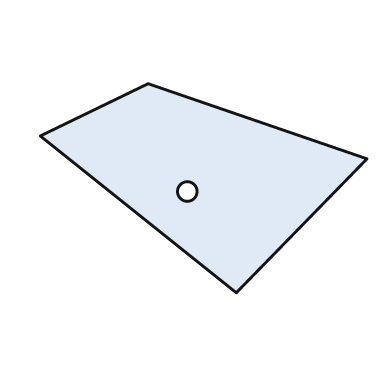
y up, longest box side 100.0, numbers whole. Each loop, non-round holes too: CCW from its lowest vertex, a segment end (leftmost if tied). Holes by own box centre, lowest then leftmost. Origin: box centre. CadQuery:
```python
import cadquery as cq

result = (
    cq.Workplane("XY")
    .moveTo(10.0, -32.0)
    .lineTo(50.0, 9.0)
    .lineTo(-17.0, 32.0)
    .lineTo(-50.0, 16.0)
    .close()
    .moveTo(-5.0, -1.0)
    .circle(3.0)
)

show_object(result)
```